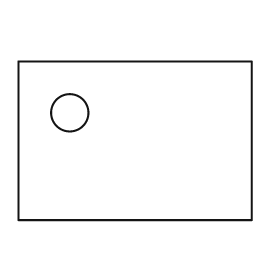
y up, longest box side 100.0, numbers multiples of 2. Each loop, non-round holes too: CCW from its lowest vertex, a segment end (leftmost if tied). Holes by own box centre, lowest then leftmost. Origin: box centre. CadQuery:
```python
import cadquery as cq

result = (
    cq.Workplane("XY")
    .moveTo(-50.0, -34.0)
    .lineTo(50.0, -34.0)
    .lineTo(50.0, 34.0)
    .lineTo(-50.0, 34.0)
    .close()
    .moveTo(-28.0, 12.0)
    .circle(8.0)
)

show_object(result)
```